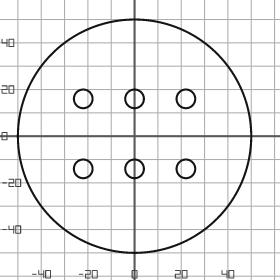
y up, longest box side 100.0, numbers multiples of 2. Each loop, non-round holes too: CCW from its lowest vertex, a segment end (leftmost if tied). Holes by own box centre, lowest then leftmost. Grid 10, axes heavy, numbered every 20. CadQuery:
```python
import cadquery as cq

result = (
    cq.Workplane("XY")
    .moveTo(0.0, 0.0)
    .circle(50.0)
    .moveTo(-22.0, -14.0)
    .circle(4.0)
    .moveTo(0.0, -14.0)
    .circle(4.0)
    .moveTo(22.0, -14.0)
    .circle(4.0)
    .moveTo(-22.0, 16.0)
    .circle(4.0)
    .moveTo(0.0, 16.0)
    .circle(4.0)
    .moveTo(22.0, 16.0)
    .circle(4.0)
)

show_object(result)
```